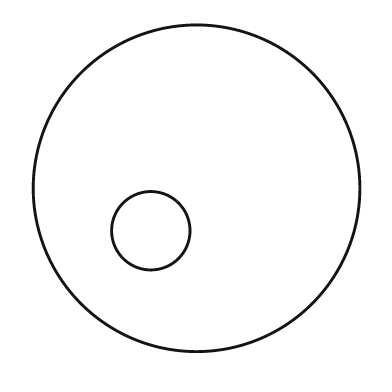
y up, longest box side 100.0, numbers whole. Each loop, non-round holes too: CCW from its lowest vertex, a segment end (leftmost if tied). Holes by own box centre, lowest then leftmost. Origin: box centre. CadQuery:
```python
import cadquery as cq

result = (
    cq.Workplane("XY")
    .moveTo(0.0, 0.0)
    .circle(50.0)
    .moveTo(-14.0, -13.0)
    .circle(12.0)
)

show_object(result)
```